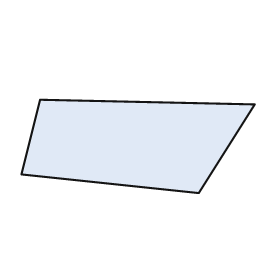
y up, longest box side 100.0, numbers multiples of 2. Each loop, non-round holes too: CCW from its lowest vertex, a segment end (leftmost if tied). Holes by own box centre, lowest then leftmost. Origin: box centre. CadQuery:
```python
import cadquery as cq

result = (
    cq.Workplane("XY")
    .moveTo(26.0, -20.0)
    .lineTo(50.0, 18.0)
    .lineTo(-42.0, 20.0)
    .lineTo(-50.0, -12.0)
    .close()
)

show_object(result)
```